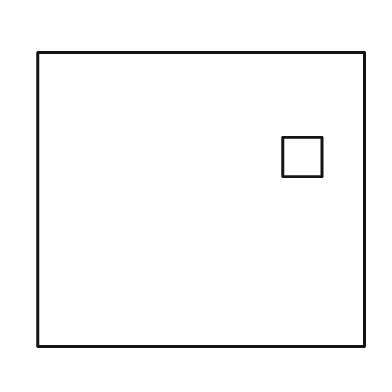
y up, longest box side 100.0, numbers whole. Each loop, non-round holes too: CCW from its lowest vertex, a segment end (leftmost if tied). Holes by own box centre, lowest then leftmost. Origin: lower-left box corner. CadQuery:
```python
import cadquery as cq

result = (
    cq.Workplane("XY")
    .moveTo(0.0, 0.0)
    .lineTo(100.0, 0.0)
    .lineTo(100.0, 90.0)
    .lineTo(0.0, 90.0)
    .close()
    .moveTo(75.0, 52.0)
    .lineTo(87.0, 52.0)
    .lineTo(87.0, 64.0)
    .lineTo(75.0, 64.0)
    .close()
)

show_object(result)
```